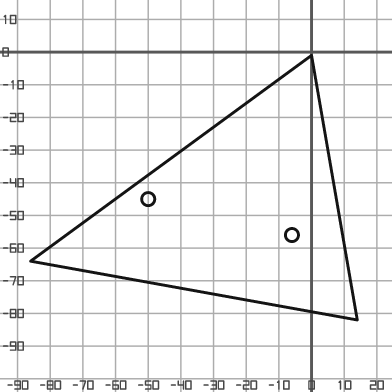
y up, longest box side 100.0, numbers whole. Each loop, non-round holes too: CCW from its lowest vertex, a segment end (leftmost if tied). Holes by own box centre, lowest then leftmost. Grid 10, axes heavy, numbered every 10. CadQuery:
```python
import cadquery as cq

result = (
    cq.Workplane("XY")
    .moveTo(14.0, -82.0)
    .lineTo(0.0, -1.0)
    .lineTo(-86.0, -64.0)
    .close()
    .moveTo(-6.0, -56.0)
    .circle(2.0)
    .moveTo(-50.0, -45.0)
    .circle(2.0)
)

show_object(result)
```